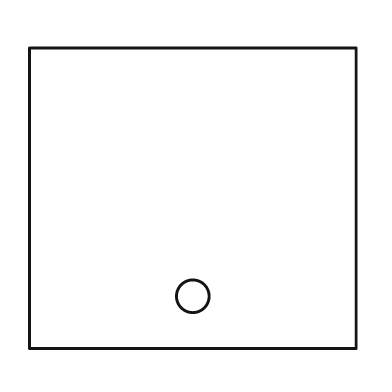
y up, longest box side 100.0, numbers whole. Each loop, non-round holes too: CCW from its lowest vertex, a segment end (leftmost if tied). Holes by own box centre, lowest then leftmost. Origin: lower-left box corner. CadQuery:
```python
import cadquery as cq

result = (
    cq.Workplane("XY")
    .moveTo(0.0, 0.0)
    .lineTo(100.0, 0.0)
    .lineTo(100.0, 92.0)
    .lineTo(0.0, 92.0)
    .close()
    .moveTo(50.0, 16.0)
    .circle(5.0)
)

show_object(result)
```